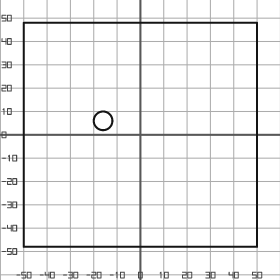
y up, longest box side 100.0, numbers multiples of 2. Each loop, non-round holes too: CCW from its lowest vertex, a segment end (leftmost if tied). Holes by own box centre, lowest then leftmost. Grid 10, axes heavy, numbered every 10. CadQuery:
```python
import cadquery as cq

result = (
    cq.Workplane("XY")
    .moveTo(-50.0, -48.0)
    .lineTo(50.0, -48.0)
    .lineTo(50.0, 48.0)
    .lineTo(-50.0, 48.0)
    .close()
    .moveTo(-16.0, 6.0)
    .circle(4.0)
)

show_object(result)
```